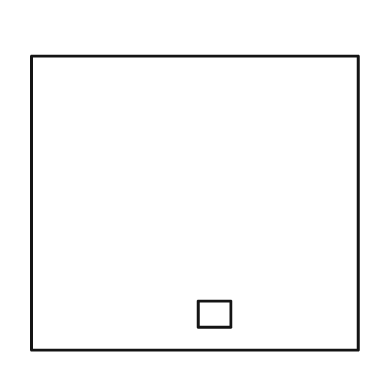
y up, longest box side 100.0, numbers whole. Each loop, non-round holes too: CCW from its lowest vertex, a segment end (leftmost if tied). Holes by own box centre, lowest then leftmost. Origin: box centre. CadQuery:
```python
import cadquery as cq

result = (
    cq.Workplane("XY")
    .moveTo(-50.0, -45.0)
    .lineTo(50.0, -45.0)
    .lineTo(50.0, 45.0)
    .lineTo(-50.0, 45.0)
    .close()
    .moveTo(1.0, -38.0)
    .lineTo(11.0, -38.0)
    .lineTo(11.0, -30.0)
    .lineTo(1.0, -30.0)
    .close()
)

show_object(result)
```